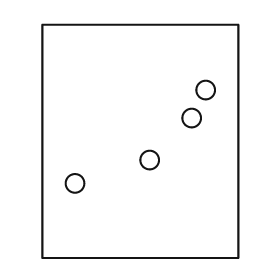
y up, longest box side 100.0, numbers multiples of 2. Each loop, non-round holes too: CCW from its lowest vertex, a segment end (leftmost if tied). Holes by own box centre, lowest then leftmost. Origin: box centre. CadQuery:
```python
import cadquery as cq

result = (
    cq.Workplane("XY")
    .moveTo(-42.0, -50.0)
    .lineTo(42.0, -50.0)
    .lineTo(42.0, 50.0)
    .lineTo(-42.0, 50.0)
    .close()
    .moveTo(-28.0, -18.0)
    .circle(4.0)
    .moveTo(4.0, -8.0)
    .circle(4.0)
    .moveTo(22.0, 10.0)
    .circle(4.0)
    .moveTo(28.0, 22.0)
    .circle(4.0)
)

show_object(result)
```